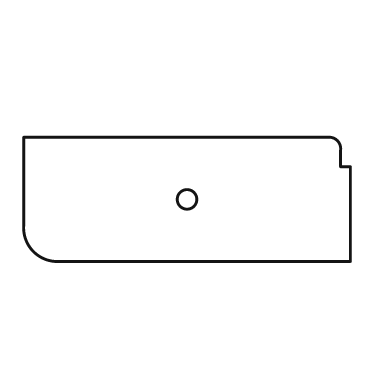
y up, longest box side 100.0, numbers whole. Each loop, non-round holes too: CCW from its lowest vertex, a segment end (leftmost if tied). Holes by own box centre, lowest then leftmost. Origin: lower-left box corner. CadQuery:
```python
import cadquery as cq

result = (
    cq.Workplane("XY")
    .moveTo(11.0, 0.0)
    .lineTo(100.0, 0.0)
    .lineTo(100.0, 29.0)
    .lineTo(97.0, 29.0)
    .lineTo(97.0, 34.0)
    .threePointArc((96.0, 37.0), (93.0, 38.0))
    .lineTo(0.0, 38.0)
    .lineTo(0.0, 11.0)
    .threePointArc((3.0, 3.0), (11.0, 0.0))
    .close()
    .moveTo(50.0, 19.0)
    .circle(3.0)
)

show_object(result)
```